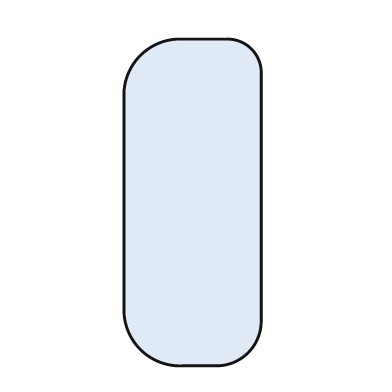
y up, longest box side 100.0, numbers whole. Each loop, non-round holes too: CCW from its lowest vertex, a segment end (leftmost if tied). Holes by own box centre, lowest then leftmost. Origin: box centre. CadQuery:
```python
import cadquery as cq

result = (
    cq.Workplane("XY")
    .moveTo(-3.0, -50.0)
    .lineTo(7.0, -50.0)
    .threePointArc((17.0, -46.0), (21.0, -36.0))
    .lineTo(21.0, 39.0)
    .threePointArc((18.0, 47.0), (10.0, 50.0))
    .lineTo(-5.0, 50.0)
    .threePointArc((-16.0, 45.0), (-21.0, 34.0))
    .lineTo(-21.0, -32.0)
    .threePointArc((-16.0, -45.0), (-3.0, -50.0))
    .close()
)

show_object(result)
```